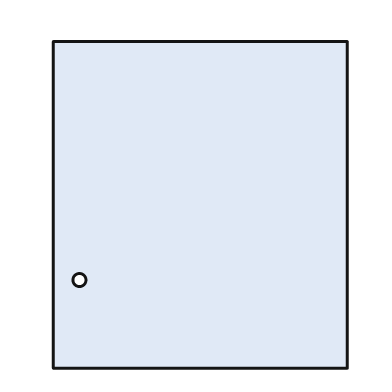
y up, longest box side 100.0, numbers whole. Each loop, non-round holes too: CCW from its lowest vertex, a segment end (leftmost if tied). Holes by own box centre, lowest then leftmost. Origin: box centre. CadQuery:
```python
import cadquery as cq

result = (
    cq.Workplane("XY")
    .moveTo(-45.0, -50.0)
    .lineTo(45.0, -50.0)
    .lineTo(45.0, 50.0)
    .lineTo(-45.0, 50.0)
    .close()
    .moveTo(-37.0, -23.0)
    .circle(2.0)
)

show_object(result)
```